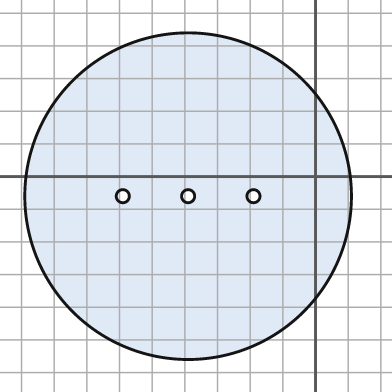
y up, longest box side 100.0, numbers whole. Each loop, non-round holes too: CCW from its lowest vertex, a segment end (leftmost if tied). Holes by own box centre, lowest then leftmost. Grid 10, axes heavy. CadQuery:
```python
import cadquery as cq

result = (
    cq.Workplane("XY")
    .moveTo(-39.0, -6.0)
    .circle(50.0)
    .moveTo(-59.0, -6.0)
    .circle(2.0)
    .moveTo(-39.0, -6.0)
    .circle(2.0)
    .moveTo(-19.0, -6.0)
    .circle(2.0)
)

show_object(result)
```